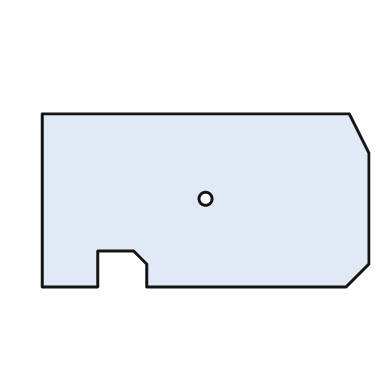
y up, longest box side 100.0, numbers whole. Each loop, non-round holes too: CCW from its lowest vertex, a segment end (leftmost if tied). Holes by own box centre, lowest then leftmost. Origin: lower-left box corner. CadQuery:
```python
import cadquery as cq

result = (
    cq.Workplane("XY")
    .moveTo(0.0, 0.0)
    .lineTo(17.0, 0.0)
    .lineTo(17.0, 11.0)
    .lineTo(28.0, 11.0)
    .lineTo(32.0, 7.0)
    .lineTo(32.0, 0.0)
    .lineTo(93.0, 0.0)
    .lineTo(100.0, 7.0)
    .lineTo(100.0, 41.0)
    .lineTo(94.0, 53.0)
    .lineTo(0.0, 53.0)
    .close()
    .moveTo(50.0, 27.0)
    .circle(2.0)
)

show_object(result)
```